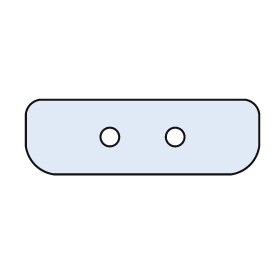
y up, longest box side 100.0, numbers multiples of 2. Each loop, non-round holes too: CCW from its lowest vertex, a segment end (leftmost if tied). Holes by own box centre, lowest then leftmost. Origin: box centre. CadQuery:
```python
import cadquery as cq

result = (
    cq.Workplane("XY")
    .moveTo(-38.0, -16.0)
    .lineTo(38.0, -16.0)
    .threePointArc((46.0, -12.0), (50.0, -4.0))
    .lineTo(50.0, 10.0)
    .threePointArc((48.0, 14.0), (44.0, 16.0))
    .lineTo(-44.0, 16.0)
    .threePointArc((-48.0, 14.0), (-50.0, 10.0))
    .lineTo(-50.0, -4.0)
    .threePointArc((-46.0, -12.0), (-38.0, -16.0))
    .close()
    .moveTo(-14.0, 0.0)
    .circle(4.0)
    .moveTo(14.0, 0.0)
    .circle(4.0)
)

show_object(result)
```